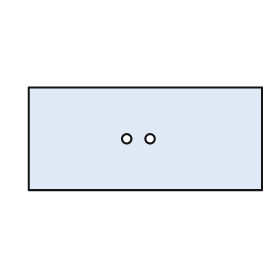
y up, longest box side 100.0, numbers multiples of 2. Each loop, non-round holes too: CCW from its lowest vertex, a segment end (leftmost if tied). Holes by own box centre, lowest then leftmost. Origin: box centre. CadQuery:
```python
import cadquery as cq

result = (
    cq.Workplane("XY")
    .moveTo(-50.0, -22.0)
    .lineTo(50.0, -22.0)
    .lineTo(50.0, 22.0)
    .lineTo(-50.0, 22.0)
    .close()
    .moveTo(-8.0, 0.0)
    .circle(2.0)
    .moveTo(2.0, 0.0)
    .circle(2.0)
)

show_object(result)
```